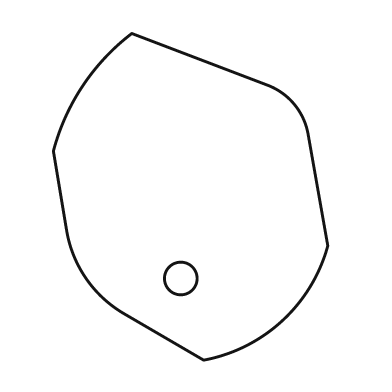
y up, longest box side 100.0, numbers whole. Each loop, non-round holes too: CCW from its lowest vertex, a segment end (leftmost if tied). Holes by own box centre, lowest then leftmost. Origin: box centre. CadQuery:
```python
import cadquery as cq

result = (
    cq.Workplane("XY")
    .moveTo(4.0, -50.0)
    .threePointArc((28.0, -38.0), (42.0, -15.0))
    .lineTo(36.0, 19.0)
    .threePointArc((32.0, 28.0), (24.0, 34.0))
    .lineTo(-18.0, 50.0)
    .threePointArc((-33.0, 34.0), (-42.0, 14.0))
    .lineTo(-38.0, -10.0)
    .threePointArc((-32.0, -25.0), (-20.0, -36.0))
    .close()
    .moveTo(-3.0, -25.0)
    .circle(5.0)
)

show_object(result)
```